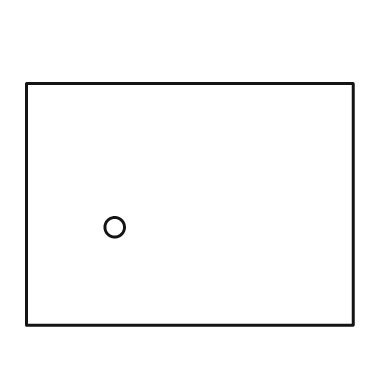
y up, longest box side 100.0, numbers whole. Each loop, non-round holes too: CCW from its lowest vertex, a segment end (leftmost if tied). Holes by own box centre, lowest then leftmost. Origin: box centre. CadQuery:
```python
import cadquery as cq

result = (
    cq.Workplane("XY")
    .moveTo(-50.0, -37.0)
    .lineTo(50.0, -37.0)
    .lineTo(50.0, 37.0)
    .lineTo(-50.0, 37.0)
    .close()
    .moveTo(-23.0, -7.0)
    .circle(3.0)
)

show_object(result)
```